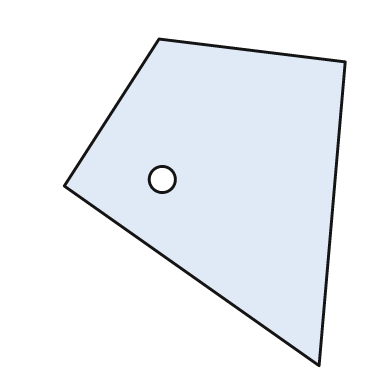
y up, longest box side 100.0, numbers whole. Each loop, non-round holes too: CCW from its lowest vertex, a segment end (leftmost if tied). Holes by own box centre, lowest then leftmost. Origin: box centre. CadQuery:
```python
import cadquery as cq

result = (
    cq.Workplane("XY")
    .moveTo(35.0, -50.0)
    .lineTo(43.0, 43.0)
    .lineTo(-14.0, 50.0)
    .lineTo(-43.0, 5.0)
    .close()
    .moveTo(-13.0, 7.0)
    .circle(4.0)
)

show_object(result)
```